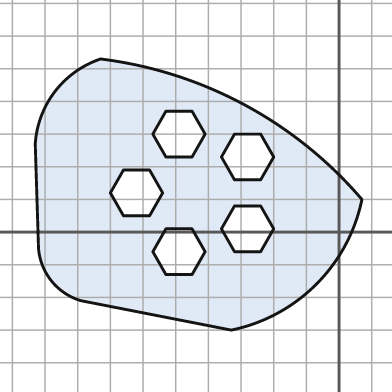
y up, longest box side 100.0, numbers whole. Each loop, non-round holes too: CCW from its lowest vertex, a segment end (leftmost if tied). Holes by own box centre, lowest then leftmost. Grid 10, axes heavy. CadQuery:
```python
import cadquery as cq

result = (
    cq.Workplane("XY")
    .moveTo(-33.0, -30.0)
    .threePointArc((-7.0, -16.0), (7.0, 10.0))
    .threePointArc((-29.0, 39.0), (-73.0, 53.0))
    .threePointArc((-87.0, 43.0), (-93.0, 27.0))
    .lineTo(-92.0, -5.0)
    .threePointArc((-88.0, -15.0), (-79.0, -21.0))
    .close()
    .moveTo(-53.0, -13.0)
    .lineTo(-45.0, -13.0)
    .lineTo(-41.0, -6.0)
    .lineTo(-45.0, 1.0)
    .lineTo(-53.0, 1.0)
    .lineTo(-57.0, -6.0)
    .close()
    .moveTo(-32.0, -6.0)
    .lineTo(-24.0, -6.0)
    .lineTo(-20.0, 1.0)
    .lineTo(-24.0, 8.0)
    .lineTo(-32.0, 8.0)
    .lineTo(-36.0, 1.0)
    .close()
    .moveTo(-66.0, 5.0)
    .lineTo(-58.0, 5.0)
    .lineTo(-54.0, 12.0)
    .lineTo(-58.0, 19.0)
    .lineTo(-66.0, 19.0)
    .lineTo(-70.0, 12.0)
    .close()
    .moveTo(-32.0, 16.0)
    .lineTo(-24.0, 16.0)
    .lineTo(-20.0, 23.0)
    .lineTo(-24.0, 30.0)
    .lineTo(-32.0, 30.0)
    .lineTo(-36.0, 23.0)
    .close()
    .moveTo(-53.0, 23.0)
    .lineTo(-45.0, 23.0)
    .lineTo(-41.0, 30.0)
    .lineTo(-45.0, 37.0)
    .lineTo(-53.0, 37.0)
    .lineTo(-57.0, 30.0)
    .close()
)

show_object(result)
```